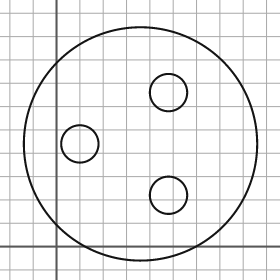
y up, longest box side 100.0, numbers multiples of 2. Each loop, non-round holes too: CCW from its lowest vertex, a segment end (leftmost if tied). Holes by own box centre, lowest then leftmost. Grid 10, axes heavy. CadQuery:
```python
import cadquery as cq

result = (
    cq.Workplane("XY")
    .moveTo(36.0, 44.0)
    .circle(50.0)
    .moveTo(48.0, 22.0)
    .circle(8.0)
    .moveTo(10.0, 44.0)
    .circle(8.0)
    .moveTo(48.0, 66.0)
    .circle(8.0)
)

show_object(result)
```